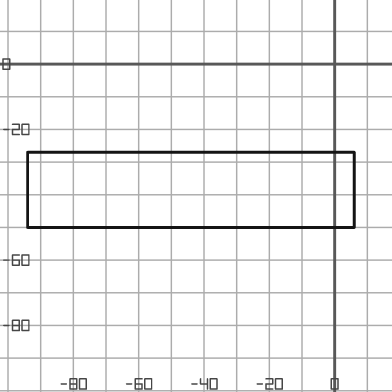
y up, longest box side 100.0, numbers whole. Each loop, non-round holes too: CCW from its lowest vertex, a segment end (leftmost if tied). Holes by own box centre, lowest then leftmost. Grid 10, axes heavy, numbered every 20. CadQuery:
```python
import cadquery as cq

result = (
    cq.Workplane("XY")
    .moveTo(-94.0, -50.0)
    .lineTo(6.0, -50.0)
    .lineTo(6.0, -27.0)
    .lineTo(-94.0, -27.0)
    .close()
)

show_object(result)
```